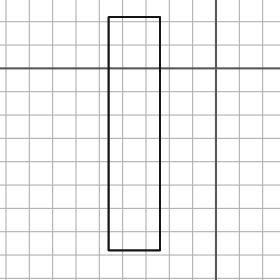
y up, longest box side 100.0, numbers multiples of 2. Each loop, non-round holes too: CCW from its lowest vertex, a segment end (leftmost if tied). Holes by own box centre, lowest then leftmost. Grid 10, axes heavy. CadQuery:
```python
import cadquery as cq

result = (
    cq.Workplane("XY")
    .moveTo(-46.0, -78.0)
    .lineTo(-24.0, -78.0)
    .lineTo(-24.0, 22.0)
    .lineTo(-46.0, 22.0)
    .close()
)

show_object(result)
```